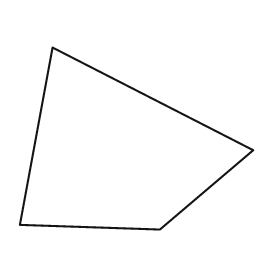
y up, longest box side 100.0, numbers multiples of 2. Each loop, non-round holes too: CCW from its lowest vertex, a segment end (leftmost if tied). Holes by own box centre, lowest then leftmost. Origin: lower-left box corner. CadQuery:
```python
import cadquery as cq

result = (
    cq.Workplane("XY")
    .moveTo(60.0, 0.0)
    .lineTo(100.0, 34.0)
    .lineTo(14.0, 78.0)
    .lineTo(0.0, 2.0)
    .close()
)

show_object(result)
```